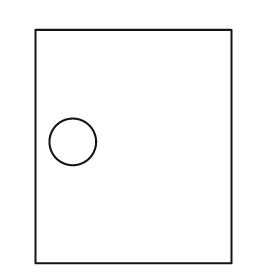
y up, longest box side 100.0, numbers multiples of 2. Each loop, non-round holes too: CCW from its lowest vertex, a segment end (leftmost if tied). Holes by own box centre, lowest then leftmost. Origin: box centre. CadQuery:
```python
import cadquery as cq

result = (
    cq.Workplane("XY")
    .moveTo(-42.0, -50.0)
    .lineTo(42.0, -50.0)
    .lineTo(42.0, 50.0)
    .lineTo(-42.0, 50.0)
    .close()
    .moveTo(-26.0, 2.0)
    .circle(10.0)
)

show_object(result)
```